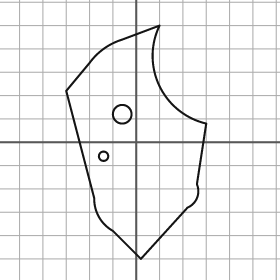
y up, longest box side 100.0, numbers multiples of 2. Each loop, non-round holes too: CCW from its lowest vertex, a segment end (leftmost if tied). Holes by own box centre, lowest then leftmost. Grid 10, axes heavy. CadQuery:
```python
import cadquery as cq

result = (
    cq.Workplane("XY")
    .moveTo(2.0, -50.0)
    .lineTo(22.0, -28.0)
    .threePointArc((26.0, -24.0), (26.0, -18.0))
    .lineTo(30.0, 8.0)
    .threePointArc((10.0, 24.0), (10.0, 50.0))
    .lineTo(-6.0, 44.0)
    .threePointArc((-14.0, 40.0), (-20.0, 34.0))
    .lineTo(-30.0, 22.0)
    .lineTo(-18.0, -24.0)
    .threePointArc((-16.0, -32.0), (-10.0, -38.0))
    .close()
    .moveTo(-14.0, -6.0)
    .circle(2.0)
    .moveTo(-6.0, 12.0)
    .circle(4.0)
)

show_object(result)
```